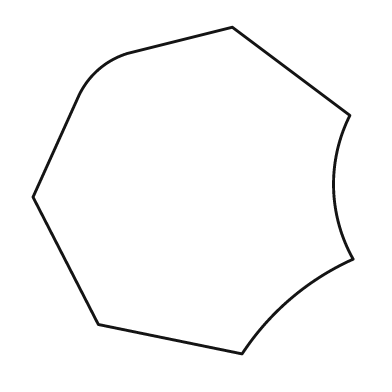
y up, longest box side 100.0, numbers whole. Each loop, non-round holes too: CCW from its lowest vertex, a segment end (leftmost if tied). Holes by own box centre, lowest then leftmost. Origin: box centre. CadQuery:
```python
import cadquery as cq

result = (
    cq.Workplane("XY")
    .moveTo(15.0, -50.0)
    .threePointArc((30.0, -33.0), (49.0, -21.0))
    .threePointArc((43.0, 1.0), (48.0, 23.0))
    .lineTo(12.0, 50.0)
    .lineTo(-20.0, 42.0)
    .threePointArc((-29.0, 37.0), (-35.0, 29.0))
    .lineTo(-49.0, -2.0)
    .lineTo(-29.0, -41.0)
    .close()
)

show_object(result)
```